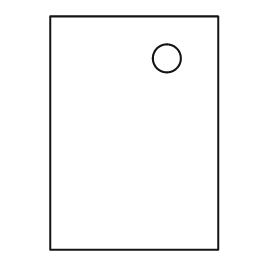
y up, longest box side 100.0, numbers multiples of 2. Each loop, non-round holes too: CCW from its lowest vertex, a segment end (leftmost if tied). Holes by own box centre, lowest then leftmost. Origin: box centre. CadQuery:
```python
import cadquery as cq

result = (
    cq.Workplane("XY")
    .moveTo(-36.0, -50.0)
    .lineTo(36.0, -50.0)
    .lineTo(36.0, 50.0)
    .lineTo(-36.0, 50.0)
    .close()
    .moveTo(14.0, 32.0)
    .circle(6.0)
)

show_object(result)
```